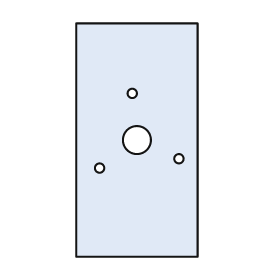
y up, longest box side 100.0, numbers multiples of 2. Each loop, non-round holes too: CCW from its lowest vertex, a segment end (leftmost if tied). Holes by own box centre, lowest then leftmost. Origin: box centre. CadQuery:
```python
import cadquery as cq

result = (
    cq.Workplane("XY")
    .moveTo(-26.0, -50.0)
    .lineTo(26.0, -50.0)
    .lineTo(26.0, 50.0)
    .lineTo(-26.0, 50.0)
    .close()
    .moveTo(-16.0, -12.0)
    .circle(2.0)
    .moveTo(18.0, -8.0)
    .circle(2.0)
    .moveTo(0.0, 0.0)
    .circle(6.0)
    .moveTo(-2.0, 20.0)
    .circle(2.0)
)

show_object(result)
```